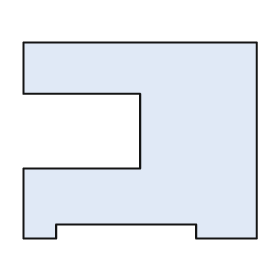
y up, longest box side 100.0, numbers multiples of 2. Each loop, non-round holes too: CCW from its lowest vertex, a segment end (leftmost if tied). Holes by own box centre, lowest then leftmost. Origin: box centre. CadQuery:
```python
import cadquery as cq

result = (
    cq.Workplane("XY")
    .moveTo(-50.0, -42.0)
    .lineTo(-36.0, -42.0)
    .lineTo(-36.0, -36.0)
    .lineTo(24.0, -36.0)
    .lineTo(24.0, -42.0)
    .lineTo(50.0, -42.0)
    .lineTo(50.0, 42.0)
    .lineTo(-50.0, 42.0)
    .lineTo(-50.0, 20.0)
    .lineTo(0.0, 20.0)
    .lineTo(0.0, -12.0)
    .lineTo(-50.0, -12.0)
    .close()
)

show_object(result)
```